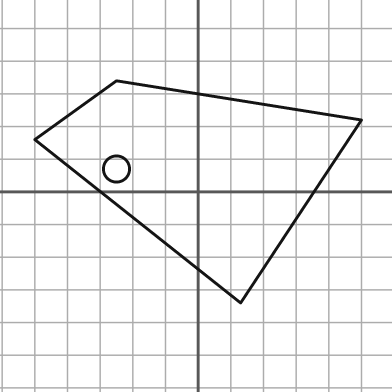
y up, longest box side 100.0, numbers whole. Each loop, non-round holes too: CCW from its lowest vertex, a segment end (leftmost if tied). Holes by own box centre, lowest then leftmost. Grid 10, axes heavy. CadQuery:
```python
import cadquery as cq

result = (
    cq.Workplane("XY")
    .moveTo(13.0, -34.0)
    .lineTo(50.0, 22.0)
    .lineTo(-25.0, 34.0)
    .lineTo(-50.0, 16.0)
    .close()
    .moveTo(-25.0, 7.0)
    .circle(4.0)
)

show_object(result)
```